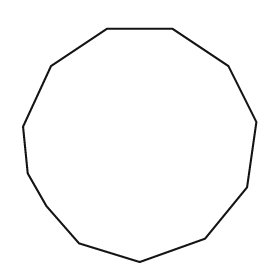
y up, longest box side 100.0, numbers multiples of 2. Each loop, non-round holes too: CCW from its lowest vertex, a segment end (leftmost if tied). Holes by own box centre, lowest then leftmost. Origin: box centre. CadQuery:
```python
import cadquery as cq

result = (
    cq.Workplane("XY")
    .moveTo(0.0, -50.0)
    .lineTo(28.0, -40.0)
    .lineTo(46.0, -18.0)
    .lineTo(50.0, 10.0)
    .lineTo(38.0, 34.0)
    .lineTo(14.0, 50.0)
    .lineTo(-14.0, 50.0)
    .lineTo(-38.0, 34.0)
    .lineTo(-50.0, 8.0)
    .lineTo(-48.0, -12.0)
    .lineTo(-40.0, -26.0)
    .lineTo(-26.0, -42.0)
    .close()
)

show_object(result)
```